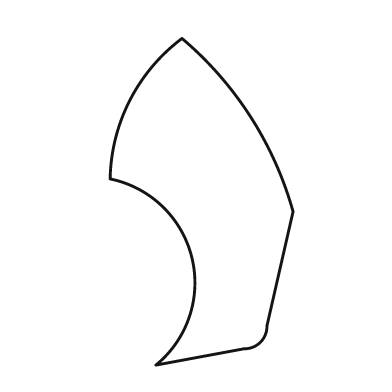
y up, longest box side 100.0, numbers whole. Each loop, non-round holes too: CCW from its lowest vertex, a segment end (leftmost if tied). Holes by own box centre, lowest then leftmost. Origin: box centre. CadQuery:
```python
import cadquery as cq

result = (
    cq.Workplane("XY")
    .moveTo(-14.0, -50.0)
    .lineTo(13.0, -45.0)
    .threePointArc((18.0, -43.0), (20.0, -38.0))
    .lineTo(28.0, -3.0)
    .threePointArc((15.0, 26.0), (-6.0, 50.0))
    .threePointArc((-22.0, 31.0), (-28.0, 7.0))
    .threePointArc((-3.0, -17.0), (-14.0, -50.0))
    .close()
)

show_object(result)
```